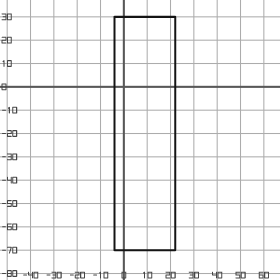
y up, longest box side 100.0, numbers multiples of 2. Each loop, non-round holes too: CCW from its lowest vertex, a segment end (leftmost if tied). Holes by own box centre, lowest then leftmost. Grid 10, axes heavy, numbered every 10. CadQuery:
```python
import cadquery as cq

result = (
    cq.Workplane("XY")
    .moveTo(-4.0, -70.0)
    .lineTo(22.0, -70.0)
    .lineTo(22.0, 30.0)
    .lineTo(-4.0, 30.0)
    .close()
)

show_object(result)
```